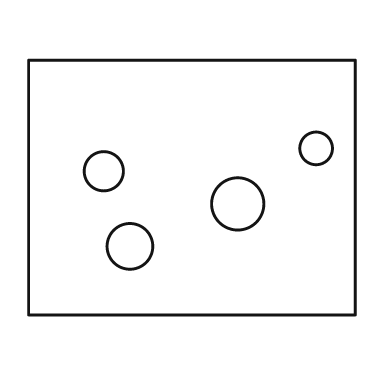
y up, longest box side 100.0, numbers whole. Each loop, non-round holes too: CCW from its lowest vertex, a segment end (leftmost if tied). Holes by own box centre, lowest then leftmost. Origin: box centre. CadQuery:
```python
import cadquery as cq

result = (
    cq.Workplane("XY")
    .moveTo(-50.0, -39.0)
    .lineTo(50.0, -39.0)
    .lineTo(50.0, 39.0)
    .lineTo(-50.0, 39.0)
    .close()
    .moveTo(-19.0, -18.0)
    .circle(7.0)
    .moveTo(14.0, -5.0)
    .circle(8.0)
    .moveTo(-27.0, 5.0)
    .circle(6.0)
    .moveTo(38.0, 12.0)
    .circle(5.0)
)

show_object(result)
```